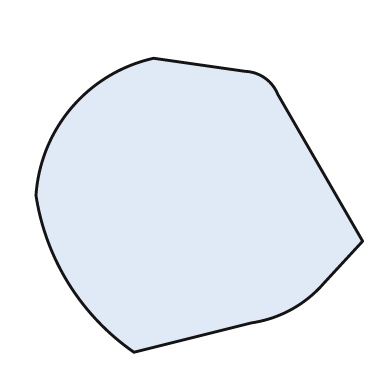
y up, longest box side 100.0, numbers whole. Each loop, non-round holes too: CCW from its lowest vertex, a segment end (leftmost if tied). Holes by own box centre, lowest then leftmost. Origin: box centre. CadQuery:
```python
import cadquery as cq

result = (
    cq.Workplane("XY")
    .moveTo(-20.0, -45.0)
    .lineTo(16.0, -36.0)
    .threePointArc((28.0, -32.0), (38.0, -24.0))
    .lineTo(50.0, -11.0)
    .lineTo(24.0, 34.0)
    .threePointArc((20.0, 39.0), (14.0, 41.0))
    .lineTo(-14.0, 45.0)
    .threePointArc((-39.0, 30.0), (-50.0, 3.0))
    .threePointArc((-40.0, -24.0), (-20.0, -45.0))
    .close()
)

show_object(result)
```